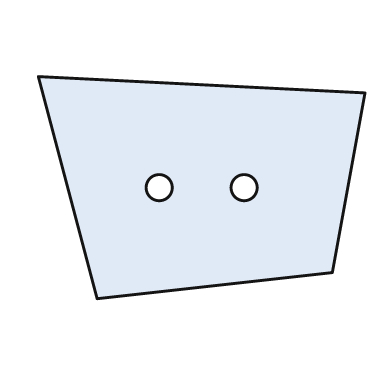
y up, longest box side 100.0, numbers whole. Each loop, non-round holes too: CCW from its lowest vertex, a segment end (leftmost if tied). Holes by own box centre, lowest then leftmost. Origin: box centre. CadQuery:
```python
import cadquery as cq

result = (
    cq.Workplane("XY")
    .moveTo(-32.0, -34.0)
    .lineTo(40.0, -26.0)
    .lineTo(50.0, 29.0)
    .lineTo(-50.0, 34.0)
    .close()
    .moveTo(-13.0, 0.0)
    .circle(4.0)
    .moveTo(13.0, 0.0)
    .circle(4.0)
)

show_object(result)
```